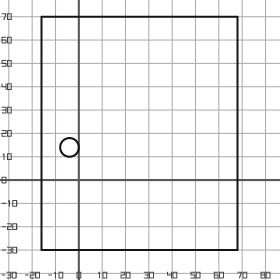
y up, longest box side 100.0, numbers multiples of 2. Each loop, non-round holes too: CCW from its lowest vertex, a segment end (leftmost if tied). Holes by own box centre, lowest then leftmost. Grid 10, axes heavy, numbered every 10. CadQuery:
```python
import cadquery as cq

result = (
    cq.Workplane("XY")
    .moveTo(-16.0, -30.0)
    .lineTo(68.0, -30.0)
    .lineTo(68.0, 70.0)
    .lineTo(-16.0, 70.0)
    .close()
    .moveTo(-4.0, 14.0)
    .circle(4.0)
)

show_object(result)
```